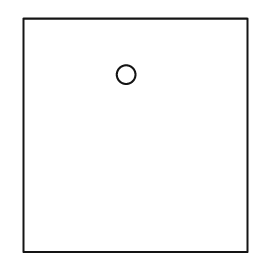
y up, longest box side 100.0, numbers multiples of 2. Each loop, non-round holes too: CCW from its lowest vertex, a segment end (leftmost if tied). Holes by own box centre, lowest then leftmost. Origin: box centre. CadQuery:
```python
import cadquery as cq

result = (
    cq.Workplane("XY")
    .moveTo(-48.0, -50.0)
    .lineTo(48.0, -50.0)
    .lineTo(48.0, 50.0)
    .lineTo(-48.0, 50.0)
    .close()
    .moveTo(-4.0, 26.0)
    .circle(4.0)
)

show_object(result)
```